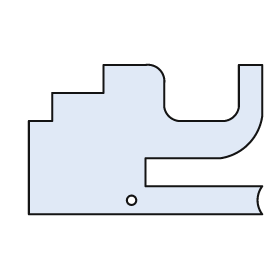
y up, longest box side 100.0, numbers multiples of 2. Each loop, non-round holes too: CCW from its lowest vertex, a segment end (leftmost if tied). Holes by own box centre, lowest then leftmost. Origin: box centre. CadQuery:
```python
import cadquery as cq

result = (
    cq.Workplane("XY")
    .moveTo(-50.0, -32.0)
    .lineTo(50.0, -32.0)
    .threePointArc((48.0, -26.0), (50.0, -20.0))
    .lineTo(0.0, -20.0)
    .lineTo(0.0, -8.0)
    .lineTo(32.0, -8.0)
    .threePointArc((44.0, -2.0), (50.0, 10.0))
    .lineTo(50.0, 32.0)
    .lineTo(40.0, 32.0)
    .lineTo(40.0, 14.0)
    .threePointArc((38.0, 10.0), (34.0, 8.0))
    .lineTo(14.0, 8.0)
    .threePointArc((10.0, 10.0), (8.0, 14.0))
    .lineTo(8.0, 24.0)
    .threePointArc((6.0, 30.0), (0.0, 32.0))
    .lineTo(-18.0, 32.0)
    .lineTo(-18.0, 20.0)
    .lineTo(-40.0, 20.0)
    .lineTo(-40.0, 8.0)
    .lineTo(-50.0, 8.0)
    .close()
    .moveTo(-6.0, -26.0)
    .circle(2.0)
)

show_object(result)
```